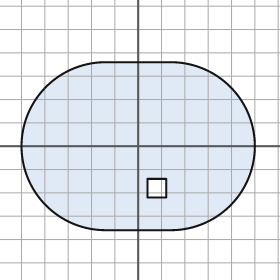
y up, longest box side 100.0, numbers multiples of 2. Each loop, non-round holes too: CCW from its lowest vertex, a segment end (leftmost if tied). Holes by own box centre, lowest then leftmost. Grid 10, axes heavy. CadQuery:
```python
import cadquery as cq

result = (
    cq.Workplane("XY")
    .moveTo(-14.0, -36.0)
    .lineTo(14.0, -36.0)
    .threePointArc((50.0, 0.0), (14.0, 36.0))
    .lineTo(-14.0, 36.0)
    .threePointArc((-50.0, 0.0), (-14.0, -36.0))
    .close()
    .moveTo(4.0, -22.0)
    .lineTo(12.0, -22.0)
    .lineTo(12.0, -14.0)
    .lineTo(4.0, -14.0)
    .close()
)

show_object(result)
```